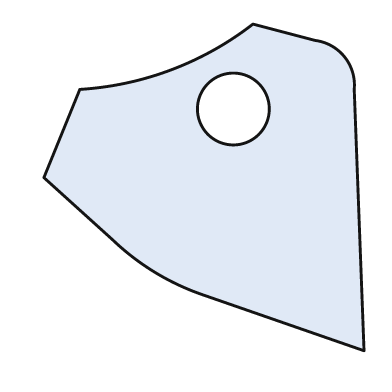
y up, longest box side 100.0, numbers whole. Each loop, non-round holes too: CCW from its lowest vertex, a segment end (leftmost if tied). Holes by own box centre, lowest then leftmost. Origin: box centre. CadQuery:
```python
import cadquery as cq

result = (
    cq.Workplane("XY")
    .moveTo(49.0, -50.0)
    .lineTo(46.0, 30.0)
    .threePointArc((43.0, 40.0), (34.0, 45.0))
    .lineTo(15.0, 50.0)
    .threePointArc((-10.0, 36.0), (-38.0, 30.0))
    .lineTo(-49.0, 3.0)
    .lineTo(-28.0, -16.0)
    .threePointArc((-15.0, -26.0), (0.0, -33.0))
    .close()
    .moveTo(9.0, 24.0)
    .circle(11.0)
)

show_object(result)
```